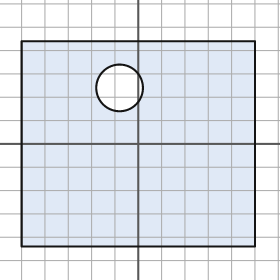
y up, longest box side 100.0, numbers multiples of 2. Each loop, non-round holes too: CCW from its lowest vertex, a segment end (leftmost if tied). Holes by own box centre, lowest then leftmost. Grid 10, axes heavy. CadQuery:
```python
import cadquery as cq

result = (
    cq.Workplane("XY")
    .moveTo(-50.0, -44.0)
    .lineTo(50.0, -44.0)
    .lineTo(50.0, 44.0)
    .lineTo(-50.0, 44.0)
    .close()
    .moveTo(-8.0, 24.0)
    .circle(10.0)
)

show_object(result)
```